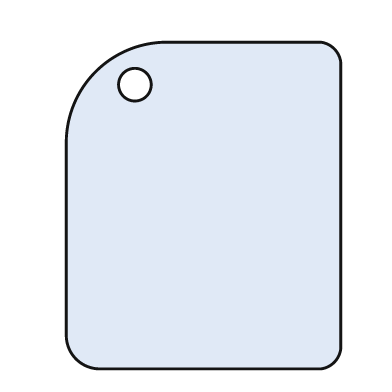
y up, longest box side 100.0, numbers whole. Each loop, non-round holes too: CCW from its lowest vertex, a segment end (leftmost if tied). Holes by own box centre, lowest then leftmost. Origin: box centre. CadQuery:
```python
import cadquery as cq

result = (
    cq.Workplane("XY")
    .moveTo(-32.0, -50.0)
    .lineTo(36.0, -50.0)
    .threePointArc((40.0, -48.0), (42.0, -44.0))
    .lineTo(42.0, 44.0)
    .threePointArc((40.0, 48.0), (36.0, 50.0))
    .lineTo(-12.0, 50.0)
    .threePointArc((-33.0, 41.0), (-42.0, 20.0))
    .lineTo(-42.0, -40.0)
    .threePointArc((-39.0, -47.0), (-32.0, -50.0))
    .close()
    .moveTo(-21.0, 37.0)
    .circle(5.0)
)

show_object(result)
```